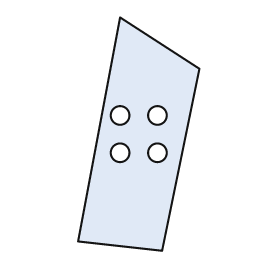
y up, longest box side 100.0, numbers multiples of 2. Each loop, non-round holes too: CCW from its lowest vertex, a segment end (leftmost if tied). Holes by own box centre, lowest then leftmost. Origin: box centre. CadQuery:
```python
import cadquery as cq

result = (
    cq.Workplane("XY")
    .moveTo(10.0, -50.0)
    .lineTo(26.0, 28.0)
    .lineTo(-8.0, 50.0)
    .lineTo(-26.0, -46.0)
    .close()
    .moveTo(-8.0, -8.0)
    .circle(4.0)
    .moveTo(8.0, -8.0)
    .circle(4.0)
    .moveTo(-8.0, 8.0)
    .circle(4.0)
    .moveTo(8.0, 8.0)
    .circle(4.0)
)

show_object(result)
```